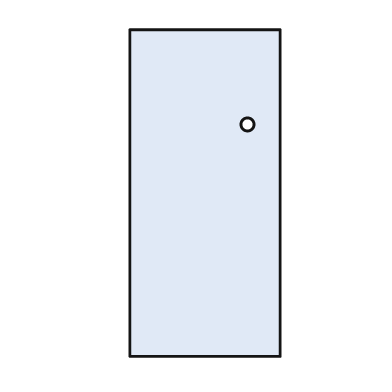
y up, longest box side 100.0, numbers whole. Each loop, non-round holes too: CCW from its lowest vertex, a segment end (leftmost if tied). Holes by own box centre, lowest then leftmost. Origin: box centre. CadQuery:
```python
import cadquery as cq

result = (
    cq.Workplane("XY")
    .moveTo(-23.0, -50.0)
    .lineTo(23.0, -50.0)
    .lineTo(23.0, 50.0)
    .lineTo(-23.0, 50.0)
    .close()
    .moveTo(13.0, 21.0)
    .circle(2.0)
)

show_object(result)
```